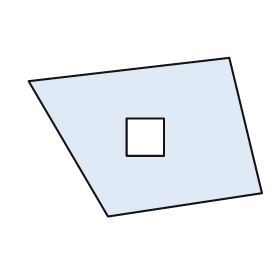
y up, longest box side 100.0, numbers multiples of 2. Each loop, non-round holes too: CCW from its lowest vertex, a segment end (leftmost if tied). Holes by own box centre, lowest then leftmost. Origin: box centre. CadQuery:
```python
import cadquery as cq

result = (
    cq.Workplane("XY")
    .moveTo(-16.0, -34.0)
    .lineTo(50.0, -24.0)
    .lineTo(36.0, 34.0)
    .lineTo(-50.0, 24.0)
    .close()
    .moveTo(-8.0, -8.0)
    .lineTo(8.0, -8.0)
    .lineTo(8.0, 8.0)
    .lineTo(-8.0, 8.0)
    .close()
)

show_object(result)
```